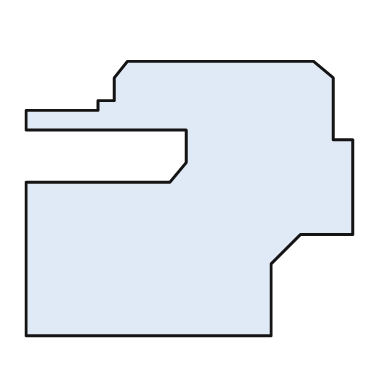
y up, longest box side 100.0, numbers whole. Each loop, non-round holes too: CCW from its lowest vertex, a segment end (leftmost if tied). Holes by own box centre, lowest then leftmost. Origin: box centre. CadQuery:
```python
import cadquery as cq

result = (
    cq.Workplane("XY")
    .moveTo(-50.0, -42.0)
    .lineTo(25.0, -42.0)
    .lineTo(25.0, -20.0)
    .lineTo(34.0, -11.0)
    .lineTo(50.0, -11.0)
    .lineTo(50.0, 18.0)
    .lineTo(44.0, 18.0)
    .lineTo(44.0, 37.0)
    .lineTo(38.0, 42.0)
    .lineTo(-19.0, 42.0)
    .lineTo(-23.0, 37.0)
    .lineTo(-23.0, 30.0)
    .lineTo(-28.0, 30.0)
    .lineTo(-28.0, 27.0)
    .lineTo(-50.0, 27.0)
    .lineTo(-50.0, 21.0)
    .lineTo(-1.0, 21.0)
    .lineTo(-1.0, 11.0)
    .lineTo(-6.0, 5.0)
    .lineTo(-50.0, 5.0)
    .close()
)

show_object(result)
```